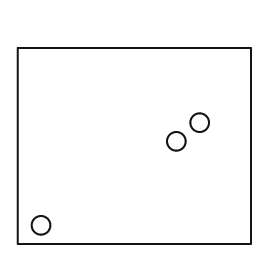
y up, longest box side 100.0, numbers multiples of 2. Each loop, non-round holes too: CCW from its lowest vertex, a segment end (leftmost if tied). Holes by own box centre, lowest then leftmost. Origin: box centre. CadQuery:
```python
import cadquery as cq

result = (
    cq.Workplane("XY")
    .moveTo(-50.0, -42.0)
    .lineTo(50.0, -42.0)
    .lineTo(50.0, 42.0)
    .lineTo(-50.0, 42.0)
    .close()
    .moveTo(-40.0, -34.0)
    .circle(4.0)
    .moveTo(18.0, 2.0)
    .circle(4.0)
    .moveTo(28.0, 10.0)
    .circle(4.0)
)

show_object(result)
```